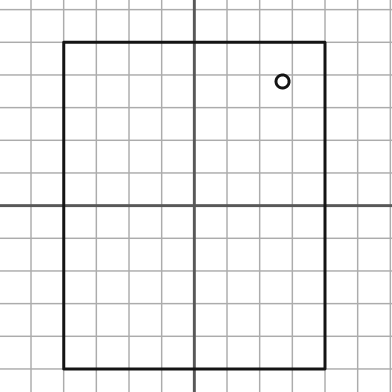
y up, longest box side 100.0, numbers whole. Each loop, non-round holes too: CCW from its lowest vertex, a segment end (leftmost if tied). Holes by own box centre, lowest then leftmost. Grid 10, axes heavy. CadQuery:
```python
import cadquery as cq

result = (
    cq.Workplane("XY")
    .moveTo(-40.0, -50.0)
    .lineTo(40.0, -50.0)
    .lineTo(40.0, 50.0)
    .lineTo(-40.0, 50.0)
    .close()
    .moveTo(27.0, 38.0)
    .circle(2.0)
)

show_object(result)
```